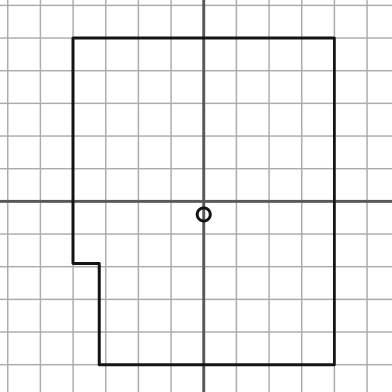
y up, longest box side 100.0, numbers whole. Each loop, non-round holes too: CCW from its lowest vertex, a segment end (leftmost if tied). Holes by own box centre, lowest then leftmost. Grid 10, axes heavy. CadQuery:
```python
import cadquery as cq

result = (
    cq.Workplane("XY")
    .moveTo(-32.0, -50.0)
    .lineTo(40.0, -50.0)
    .lineTo(40.0, 50.0)
    .lineTo(-40.0, 50.0)
    .lineTo(-40.0, -19.0)
    .lineTo(-32.0, -19.0)
    .close()
    .moveTo(0.0, -4.0)
    .circle(2.0)
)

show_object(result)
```